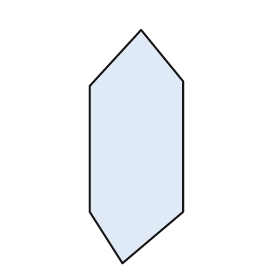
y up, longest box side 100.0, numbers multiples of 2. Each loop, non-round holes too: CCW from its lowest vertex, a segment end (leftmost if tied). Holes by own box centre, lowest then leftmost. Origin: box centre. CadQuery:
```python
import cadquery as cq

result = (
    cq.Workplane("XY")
    .moveTo(-6.0, -50.0)
    .lineTo(20.0, -28.0)
    .lineTo(20.0, 28.0)
    .lineTo(2.0, 50.0)
    .lineTo(-20.0, 26.0)
    .lineTo(-20.0, -28.0)
    .close()
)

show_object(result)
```